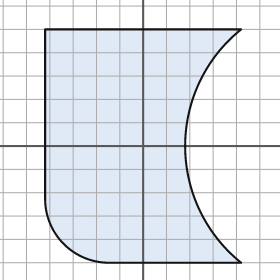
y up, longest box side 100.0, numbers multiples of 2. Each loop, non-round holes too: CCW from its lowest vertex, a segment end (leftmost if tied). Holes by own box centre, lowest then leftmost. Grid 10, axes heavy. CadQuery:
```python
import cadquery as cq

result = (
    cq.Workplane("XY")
    .moveTo(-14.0, -50.0)
    .lineTo(42.0, -50.0)
    .threePointArc((18.0, 0.0), (42.0, 50.0))
    .lineTo(-42.0, 50.0)
    .lineTo(-42.0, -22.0)
    .threePointArc((-34.0, -42.0), (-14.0, -50.0))
    .close()
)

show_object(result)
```